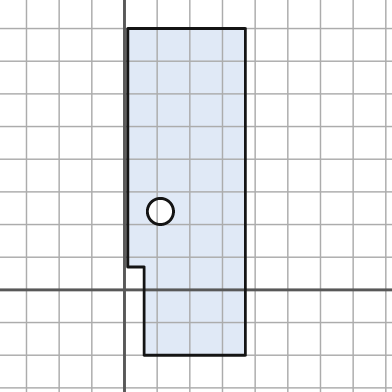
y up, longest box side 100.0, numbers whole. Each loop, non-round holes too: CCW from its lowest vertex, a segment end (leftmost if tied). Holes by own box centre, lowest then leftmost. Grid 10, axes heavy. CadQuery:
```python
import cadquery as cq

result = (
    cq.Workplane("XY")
    .moveTo(6.0, -20.0)
    .lineTo(37.0, -20.0)
    .lineTo(37.0, 80.0)
    .lineTo(1.0, 80.0)
    .lineTo(1.0, 7.0)
    .lineTo(6.0, 7.0)
    .close()
    .moveTo(11.0, 24.0)
    .circle(4.0)
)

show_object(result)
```